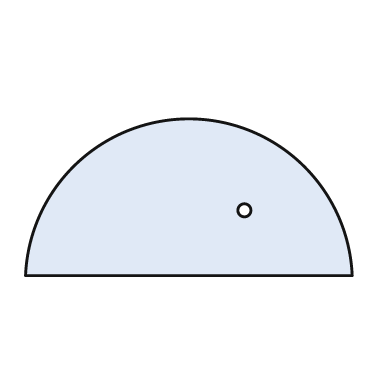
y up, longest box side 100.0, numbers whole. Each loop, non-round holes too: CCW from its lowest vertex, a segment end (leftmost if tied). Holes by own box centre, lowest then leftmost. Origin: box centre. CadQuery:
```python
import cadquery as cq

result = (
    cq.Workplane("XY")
    .moveTo(-50.0, -24.0)
    .lineTo(50.0, -24.0)
    .threePointArc((0.0, 24.0), (-50.0, -24.0))
    .close()
    .moveTo(17.0, -4.0)
    .circle(2.0)
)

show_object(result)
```